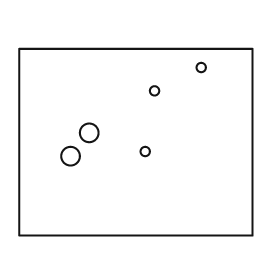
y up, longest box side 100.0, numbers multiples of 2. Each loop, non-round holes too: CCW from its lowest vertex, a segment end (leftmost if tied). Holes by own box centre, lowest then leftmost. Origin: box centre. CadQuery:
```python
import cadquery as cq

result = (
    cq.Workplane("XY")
    .moveTo(-50.0, -40.0)
    .lineTo(50.0, -40.0)
    .lineTo(50.0, 40.0)
    .lineTo(-50.0, 40.0)
    .close()
    .moveTo(-28.0, -6.0)
    .circle(4.0)
    .moveTo(4.0, -4.0)
    .circle(2.0)
    .moveTo(-20.0, 4.0)
    .circle(4.0)
    .moveTo(8.0, 22.0)
    .circle(2.0)
    .moveTo(28.0, 32.0)
    .circle(2.0)
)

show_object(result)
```